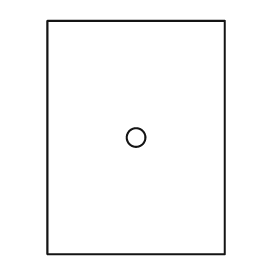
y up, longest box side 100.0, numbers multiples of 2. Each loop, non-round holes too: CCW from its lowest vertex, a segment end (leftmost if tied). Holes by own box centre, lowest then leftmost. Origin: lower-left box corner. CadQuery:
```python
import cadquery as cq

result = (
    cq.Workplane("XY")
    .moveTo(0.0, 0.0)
    .lineTo(76.0, 0.0)
    .lineTo(76.0, 100.0)
    .lineTo(0.0, 100.0)
    .close()
    .moveTo(38.0, 50.0)
    .circle(4.0)
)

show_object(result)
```